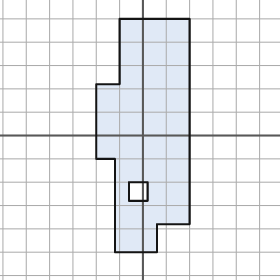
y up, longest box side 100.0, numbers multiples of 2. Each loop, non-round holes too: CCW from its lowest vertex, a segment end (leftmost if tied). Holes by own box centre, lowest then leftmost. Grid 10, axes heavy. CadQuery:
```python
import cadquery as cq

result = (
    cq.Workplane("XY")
    .moveTo(-12.0, -50.0)
    .lineTo(6.0, -50.0)
    .lineTo(6.0, -38.0)
    .lineTo(20.0, -38.0)
    .lineTo(20.0, 50.0)
    .lineTo(-10.0, 50.0)
    .lineTo(-10.0, 22.0)
    .lineTo(-20.0, 22.0)
    .lineTo(-20.0, -10.0)
    .lineTo(-12.0, -10.0)
    .close()
    .moveTo(-6.0, -28.0)
    .lineTo(2.0, -28.0)
    .lineTo(2.0, -20.0)
    .lineTo(-6.0, -20.0)
    .close()
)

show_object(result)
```